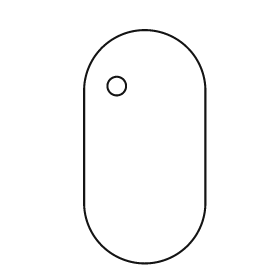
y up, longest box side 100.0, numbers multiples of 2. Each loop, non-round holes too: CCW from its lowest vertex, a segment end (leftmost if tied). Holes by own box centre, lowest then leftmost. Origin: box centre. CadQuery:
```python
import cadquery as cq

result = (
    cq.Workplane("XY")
    .moveTo(-26.0, -24.0)
    .threePointArc((0.0, -50.0), (26.0, -24.0))
    .lineTo(26.0, 24.0)
    .threePointArc((0.0, 50.0), (-26.0, 24.0))
    .close()
    .moveTo(-12.0, 26.0)
    .circle(4.0)
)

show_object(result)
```